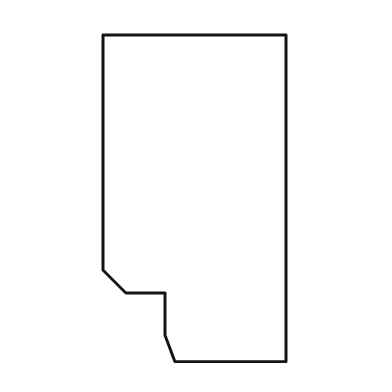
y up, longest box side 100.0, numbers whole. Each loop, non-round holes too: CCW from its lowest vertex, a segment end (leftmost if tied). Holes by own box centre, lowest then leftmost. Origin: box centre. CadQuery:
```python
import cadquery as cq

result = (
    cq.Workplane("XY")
    .moveTo(-6.0, -50.0)
    .lineTo(28.0, -50.0)
    .lineTo(28.0, 50.0)
    .lineTo(-28.0, 50.0)
    .lineTo(-28.0, -22.0)
    .lineTo(-21.0, -29.0)
    .lineTo(-9.0, -29.0)
    .lineTo(-9.0, -42.0)
    .close()
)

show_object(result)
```